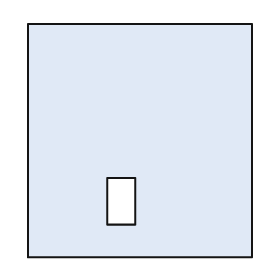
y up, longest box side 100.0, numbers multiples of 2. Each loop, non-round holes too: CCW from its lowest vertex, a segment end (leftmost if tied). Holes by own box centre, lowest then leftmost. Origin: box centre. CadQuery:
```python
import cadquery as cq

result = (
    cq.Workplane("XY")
    .moveTo(-48.0, -50.0)
    .lineTo(48.0, -50.0)
    .lineTo(48.0, 50.0)
    .lineTo(-48.0, 50.0)
    .close()
    .moveTo(-14.0, -36.0)
    .lineTo(-2.0, -36.0)
    .lineTo(-2.0, -16.0)
    .lineTo(-14.0, -16.0)
    .close()
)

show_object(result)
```